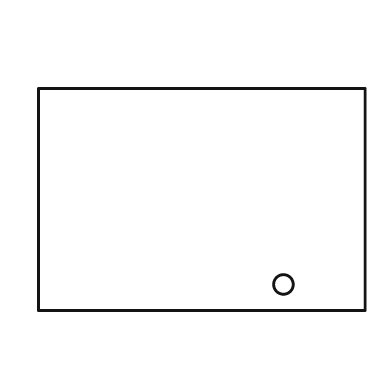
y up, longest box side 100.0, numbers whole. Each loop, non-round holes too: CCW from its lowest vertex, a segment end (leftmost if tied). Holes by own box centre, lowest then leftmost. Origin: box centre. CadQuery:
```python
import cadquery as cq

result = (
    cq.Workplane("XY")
    .moveTo(-50.0, -34.0)
    .lineTo(50.0, -34.0)
    .lineTo(50.0, 34.0)
    .lineTo(-50.0, 34.0)
    .close()
    .moveTo(25.0, -26.0)
    .circle(3.0)
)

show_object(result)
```